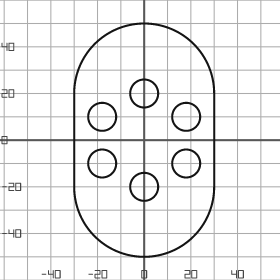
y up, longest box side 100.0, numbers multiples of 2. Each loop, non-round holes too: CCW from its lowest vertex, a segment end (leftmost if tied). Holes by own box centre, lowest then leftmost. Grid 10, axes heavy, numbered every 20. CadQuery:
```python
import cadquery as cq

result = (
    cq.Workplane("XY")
    .moveTo(-30.0, -20.0)
    .threePointArc((0.0, -50.0), (30.0, -20.0))
    .lineTo(30.0, 20.0)
    .threePointArc((0.0, 50.0), (-30.0, 20.0))
    .close()
    .moveTo(0.0, -20.0)
    .circle(6.0)
    .moveTo(-18.0, -10.0)
    .circle(6.0)
    .moveTo(18.0, -10.0)
    .circle(6.0)
    .moveTo(-18.0, 10.0)
    .circle(6.0)
    .moveTo(18.0, 10.0)
    .circle(6.0)
    .moveTo(0.0, 20.0)
    .circle(6.0)
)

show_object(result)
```